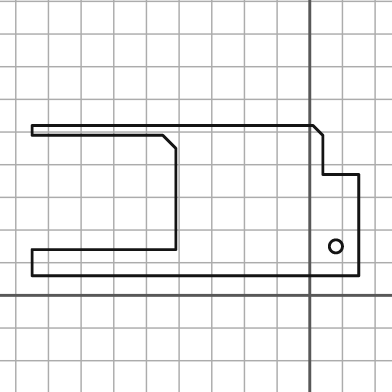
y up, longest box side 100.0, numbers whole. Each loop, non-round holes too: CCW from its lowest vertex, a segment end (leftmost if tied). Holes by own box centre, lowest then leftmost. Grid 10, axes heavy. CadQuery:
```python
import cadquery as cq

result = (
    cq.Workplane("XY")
    .moveTo(-85.0, 6.0)
    .lineTo(15.0, 6.0)
    .lineTo(15.0, 37.0)
    .lineTo(4.0, 37.0)
    .lineTo(4.0, 49.0)
    .lineTo(1.0, 52.0)
    .lineTo(-85.0, 52.0)
    .lineTo(-85.0, 49.0)
    .lineTo(-45.0, 49.0)
    .lineTo(-41.0, 45.0)
    .lineTo(-41.0, 14.0)
    .lineTo(-85.0, 14.0)
    .close()
    .moveTo(8.0, 15.0)
    .circle(2.0)
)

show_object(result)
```